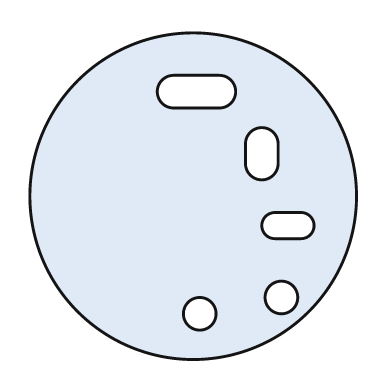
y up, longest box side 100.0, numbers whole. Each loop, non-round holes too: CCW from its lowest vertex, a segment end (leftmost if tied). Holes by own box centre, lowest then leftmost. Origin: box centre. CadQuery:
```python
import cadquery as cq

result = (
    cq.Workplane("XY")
    .moveTo(0.0, 0.0)
    .circle(50.0)
    .moveTo(2.0, -36.0)
    .circle(5.0)
    .moveTo(27.0, -31.0)
    .circle(5.0)
    .moveTo(25.0, -13.0)
    .lineTo(33.0, -13.0)
    .threePointArc((37.0, -9.0), (33.0, -5.0))
    .lineTo(25.0, -5.0)
    .threePointArc((21.0, -9.0), (25.0, -13.0))
    .close()
    .moveTo(16.0, 10.0)
    .threePointArc((21.0, 5.0), (26.0, 10.0))
    .lineTo(26.0, 16.0)
    .threePointArc((21.0, 21.0), (16.0, 16.0))
    .close()
    .moveTo(-6.0, 27.0)
    .lineTo(8.0, 27.0)
    .threePointArc((13.0, 32.0), (8.0, 37.0))
    .lineTo(-6.0, 37.0)
    .threePointArc((-11.0, 32.0), (-6.0, 27.0))
    .close()
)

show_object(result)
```